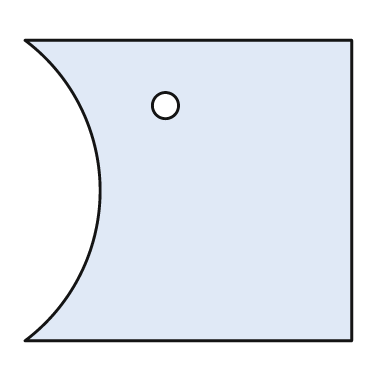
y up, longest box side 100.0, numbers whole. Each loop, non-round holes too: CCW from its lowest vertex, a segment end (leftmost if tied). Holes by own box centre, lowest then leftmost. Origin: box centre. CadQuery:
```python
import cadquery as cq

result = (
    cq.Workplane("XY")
    .moveTo(-50.0, -46.0)
    .lineTo(50.0, -46.0)
    .lineTo(50.0, 46.0)
    .lineTo(-50.0, 46.0)
    .threePointArc((-27.0, 0.0), (-50.0, -46.0))
    .close()
    .moveTo(-7.0, 26.0)
    .circle(4.0)
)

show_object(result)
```